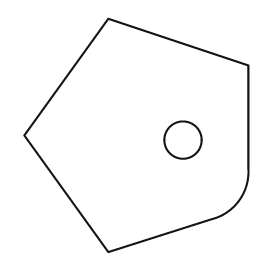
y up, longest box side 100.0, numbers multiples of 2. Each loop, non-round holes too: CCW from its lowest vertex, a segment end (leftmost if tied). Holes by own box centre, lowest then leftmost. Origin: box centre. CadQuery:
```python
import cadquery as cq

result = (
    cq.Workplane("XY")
    .moveTo(-12.0, -50.0)
    .lineTo(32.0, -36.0)
    .threePointArc((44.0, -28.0), (48.0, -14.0))
    .lineTo(48.0, 30.0)
    .lineTo(-12.0, 50.0)
    .lineTo(-48.0, 0.0)
    .close()
    .moveTo(20.0, -2.0)
    .circle(8.0)
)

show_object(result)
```